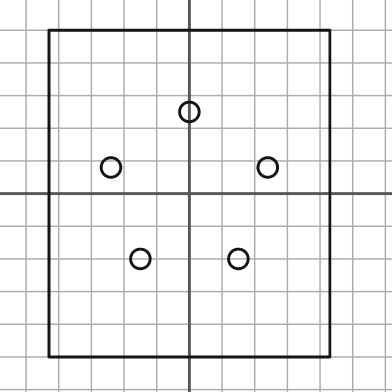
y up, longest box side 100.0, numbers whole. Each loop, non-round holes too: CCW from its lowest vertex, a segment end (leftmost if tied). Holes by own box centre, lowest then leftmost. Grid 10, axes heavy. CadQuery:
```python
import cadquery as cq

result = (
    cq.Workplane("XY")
    .moveTo(-43.0, -50.0)
    .lineTo(43.0, -50.0)
    .lineTo(43.0, 50.0)
    .lineTo(-43.0, 50.0)
    .close()
    .moveTo(-15.0, -20.0)
    .circle(3.0)
    .moveTo(15.0, -20.0)
    .circle(3.0)
    .moveTo(-24.0, 8.0)
    .circle(3.0)
    .moveTo(24.0, 8.0)
    .circle(3.0)
    .moveTo(0.0, 25.0)
    .circle(3.0)
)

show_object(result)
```